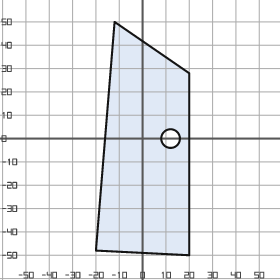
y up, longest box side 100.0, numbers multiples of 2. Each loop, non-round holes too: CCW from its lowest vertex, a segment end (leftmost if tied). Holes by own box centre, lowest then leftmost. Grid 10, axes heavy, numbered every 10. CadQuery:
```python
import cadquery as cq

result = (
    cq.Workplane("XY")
    .moveTo(20.0, -50.0)
    .lineTo(20.0, 28.0)
    .lineTo(-12.0, 50.0)
    .lineTo(-20.0, -48.0)
    .close()
    .moveTo(12.0, 0.0)
    .circle(4.0)
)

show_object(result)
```